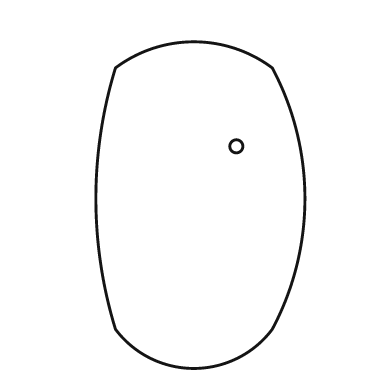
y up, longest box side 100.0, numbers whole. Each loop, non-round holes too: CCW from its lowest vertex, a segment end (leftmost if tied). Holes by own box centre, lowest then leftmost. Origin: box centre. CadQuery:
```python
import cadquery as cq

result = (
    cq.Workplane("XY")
    .moveTo(-26.0, -38.0)
    .threePointArc((-2.0, -50.0), (22.0, -38.0))
    .threePointArc((32.0, 2.0), (22.0, 42.0))
    .threePointArc((-2.0, 50.0), (-26.0, 42.0))
    .threePointArc((-32.0, 2.0), (-26.0, -38.0))
    .close()
    .moveTo(11.0, 18.0)
    .circle(2.0)
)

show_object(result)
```